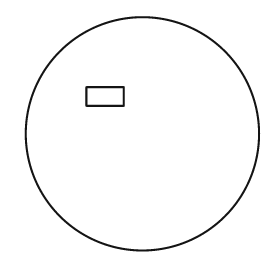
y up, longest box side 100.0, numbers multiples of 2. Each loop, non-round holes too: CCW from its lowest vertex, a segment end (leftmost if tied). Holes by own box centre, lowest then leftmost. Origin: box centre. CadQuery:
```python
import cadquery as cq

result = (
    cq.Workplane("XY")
    .moveTo(0.0, 0.0)
    .circle(50.0)
    .moveTo(-24.0, 12.0)
    .lineTo(-8.0, 12.0)
    .lineTo(-8.0, 20.0)
    .lineTo(-24.0, 20.0)
    .close()
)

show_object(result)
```